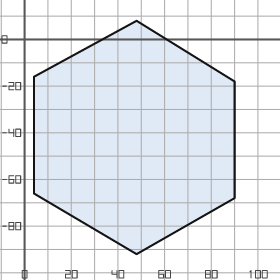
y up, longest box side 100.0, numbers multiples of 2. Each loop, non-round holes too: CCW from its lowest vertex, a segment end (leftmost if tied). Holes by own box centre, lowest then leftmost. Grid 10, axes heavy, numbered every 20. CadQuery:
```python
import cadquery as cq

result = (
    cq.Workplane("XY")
    .moveTo(48.0, -92.0)
    .lineTo(90.0, -68.0)
    .lineTo(90.0, -18.0)
    .lineTo(48.0, 8.0)
    .lineTo(4.0, -16.0)
    .lineTo(4.0, -66.0)
    .close()
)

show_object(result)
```